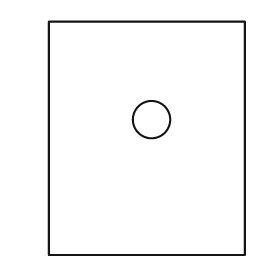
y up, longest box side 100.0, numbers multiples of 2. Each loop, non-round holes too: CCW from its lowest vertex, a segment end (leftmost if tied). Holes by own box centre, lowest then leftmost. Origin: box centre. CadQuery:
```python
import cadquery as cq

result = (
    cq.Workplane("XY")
    .moveTo(-42.0, -50.0)
    .lineTo(42.0, -50.0)
    .lineTo(42.0, 50.0)
    .lineTo(-42.0, 50.0)
    .close()
    .moveTo(2.0, 8.0)
    .circle(8.0)
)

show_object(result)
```